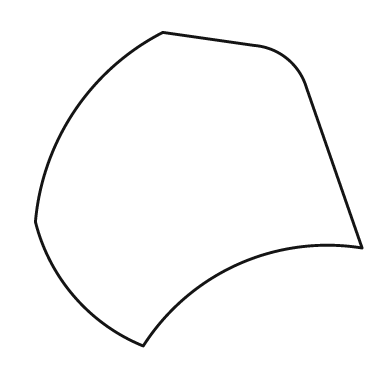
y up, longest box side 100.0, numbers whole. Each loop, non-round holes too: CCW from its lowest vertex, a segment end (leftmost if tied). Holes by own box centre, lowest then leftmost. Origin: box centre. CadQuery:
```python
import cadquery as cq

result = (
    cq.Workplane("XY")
    .moveTo(-17.0, -48.0)
    .threePointArc((12.0, -23.0), (50.0, -18.0))
    .lineTo(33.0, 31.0)
    .threePointArc((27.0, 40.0), (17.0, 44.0))
    .lineTo(-11.0, 48.0)
    .threePointArc((-38.0, 24.0), (-50.0, -10.0))
    .threePointArc((-38.0, -33.0), (-17.0, -48.0))
    .close()
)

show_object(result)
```